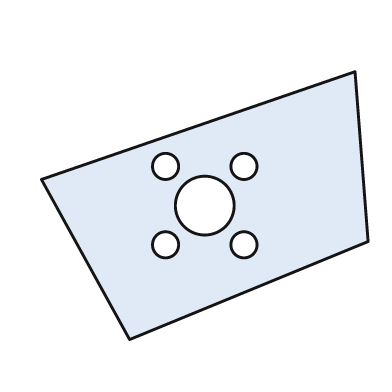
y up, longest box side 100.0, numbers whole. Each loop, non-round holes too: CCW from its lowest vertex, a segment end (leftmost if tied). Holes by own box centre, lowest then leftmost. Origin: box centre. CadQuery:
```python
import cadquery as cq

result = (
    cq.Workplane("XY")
    .moveTo(-23.0, -41.0)
    .lineTo(50.0, -11.0)
    .lineTo(46.0, 41.0)
    .lineTo(-50.0, 8.0)
    .close()
    .moveTo(-12.0, -12.0)
    .circle(4.0)
    .moveTo(12.0, -12.0)
    .circle(4.0)
    .moveTo(0.0, 0.0)
    .circle(9.0)
    .moveTo(-12.0, 12.0)
    .circle(4.0)
    .moveTo(12.0, 12.0)
    .circle(4.0)
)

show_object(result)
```